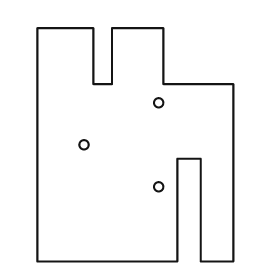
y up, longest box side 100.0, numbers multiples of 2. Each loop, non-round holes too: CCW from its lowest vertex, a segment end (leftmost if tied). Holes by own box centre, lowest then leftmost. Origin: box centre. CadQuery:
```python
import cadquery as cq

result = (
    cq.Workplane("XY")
    .moveTo(-42.0, -50.0)
    .lineTo(18.0, -50.0)
    .lineTo(18.0, -6.0)
    .lineTo(28.0, -6.0)
    .lineTo(28.0, -50.0)
    .lineTo(42.0, -50.0)
    .lineTo(42.0, 26.0)
    .lineTo(12.0, 26.0)
    .lineTo(12.0, 50.0)
    .lineTo(-10.0, 50.0)
    .lineTo(-10.0, 26.0)
    .lineTo(-18.0, 26.0)
    .lineTo(-18.0, 50.0)
    .lineTo(-42.0, 50.0)
    .close()
    .moveTo(10.0, -18.0)
    .circle(2.0)
    .moveTo(-22.0, 0.0)
    .circle(2.0)
    .moveTo(10.0, 18.0)
    .circle(2.0)
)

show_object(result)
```